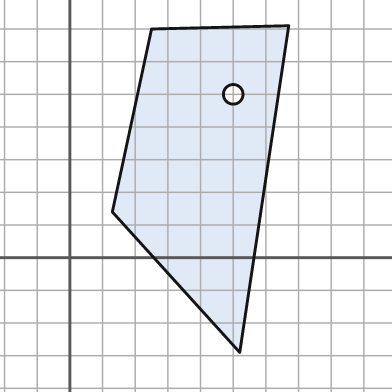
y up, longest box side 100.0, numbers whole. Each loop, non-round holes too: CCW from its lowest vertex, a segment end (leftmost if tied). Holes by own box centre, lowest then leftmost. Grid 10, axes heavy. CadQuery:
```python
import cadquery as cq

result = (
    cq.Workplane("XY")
    .moveTo(52.0, -29.0)
    .lineTo(67.0, 71.0)
    .lineTo(25.0, 70.0)
    .lineTo(13.0, 14.0)
    .close()
    .moveTo(50.0, 50.0)
    .circle(3.0)
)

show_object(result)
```